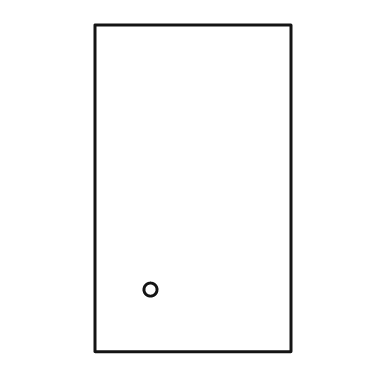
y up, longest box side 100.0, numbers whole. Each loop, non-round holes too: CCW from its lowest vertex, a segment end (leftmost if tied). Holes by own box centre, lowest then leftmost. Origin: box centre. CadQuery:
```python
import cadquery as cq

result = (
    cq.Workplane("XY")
    .moveTo(-30.0, -50.0)
    .lineTo(30.0, -50.0)
    .lineTo(30.0, 50.0)
    .lineTo(-30.0, 50.0)
    .close()
    .moveTo(-13.0, -31.0)
    .circle(2.0)
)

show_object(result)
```